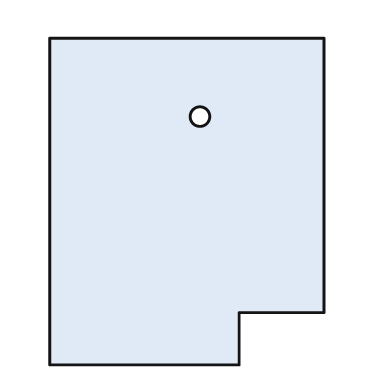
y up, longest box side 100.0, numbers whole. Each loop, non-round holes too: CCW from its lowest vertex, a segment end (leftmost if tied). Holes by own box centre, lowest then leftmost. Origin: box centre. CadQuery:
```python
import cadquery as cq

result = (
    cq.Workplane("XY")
    .moveTo(-42.0, -50.0)
    .lineTo(16.0, -50.0)
    .lineTo(16.0, -34.0)
    .lineTo(42.0, -34.0)
    .lineTo(42.0, 50.0)
    .lineTo(-42.0, 50.0)
    .close()
    .moveTo(4.0, 26.0)
    .circle(3.0)
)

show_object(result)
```